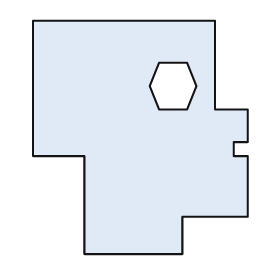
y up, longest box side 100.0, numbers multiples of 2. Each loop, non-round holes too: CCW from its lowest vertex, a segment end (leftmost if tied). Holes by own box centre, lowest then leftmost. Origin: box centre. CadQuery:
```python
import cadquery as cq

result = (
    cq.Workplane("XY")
    .moveTo(-24.0, -50.0)
    .lineTo(18.0, -50.0)
    .lineTo(18.0, -34.0)
    .lineTo(46.0, -34.0)
    .lineTo(46.0, -8.0)
    .lineTo(40.0, -8.0)
    .lineTo(40.0, -2.0)
    .lineTo(46.0, -2.0)
    .lineTo(46.0, 12.0)
    .lineTo(32.0, 12.0)
    .lineTo(32.0, 50.0)
    .lineTo(-46.0, 50.0)
    .lineTo(-46.0, -8.0)
    .lineTo(-24.0, -8.0)
    .close()
    .moveTo(8.0, 12.0)
    .lineTo(20.0, 12.0)
    .lineTo(24.0, 22.0)
    .lineTo(20.0, 32.0)
    .lineTo(8.0, 32.0)
    .lineTo(4.0, 22.0)
    .close()
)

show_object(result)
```